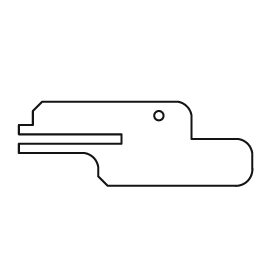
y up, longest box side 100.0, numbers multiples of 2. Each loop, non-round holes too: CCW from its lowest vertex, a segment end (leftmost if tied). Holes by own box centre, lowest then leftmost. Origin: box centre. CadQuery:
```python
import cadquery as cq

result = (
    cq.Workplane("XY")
    .moveTo(-12.0, -18.0)
    .lineTo(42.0, -18.0)
    .threePointArc((48.0, -16.0), (50.0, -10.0))
    .lineTo(50.0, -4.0)
    .threePointArc((48.0, 0.0), (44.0, 2.0))
    .lineTo(24.0, 2.0)
    .lineTo(24.0, 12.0)
    .threePointArc((22.0, 16.0), (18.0, 18.0))
    .lineTo(-40.0, 18.0)
    .lineTo(-44.0, 14.0)
    .lineTo(-44.0, 8.0)
    .lineTo(-50.0, 8.0)
    .lineTo(-50.0, 4.0)
    .lineTo(-6.0, 4.0)
    .lineTo(-6.0, 0.0)
    .lineTo(-50.0, 0.0)
    .lineTo(-50.0, -4.0)
    .lineTo(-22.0, -4.0)
    .threePointArc((-18.0, -6.0), (-16.0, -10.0))
    .lineTo(-16.0, -14.0)
    .close()
    .moveTo(10.0, 12.0)
    .circle(2.0)
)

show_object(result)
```